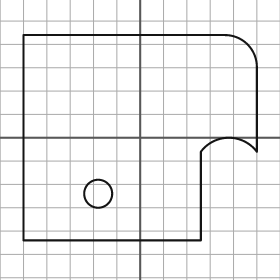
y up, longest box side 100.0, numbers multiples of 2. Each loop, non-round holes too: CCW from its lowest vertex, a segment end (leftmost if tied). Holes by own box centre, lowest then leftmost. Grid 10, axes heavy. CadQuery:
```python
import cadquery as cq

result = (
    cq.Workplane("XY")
    .moveTo(-50.0, -44.0)
    .lineTo(26.0, -44.0)
    .lineTo(26.0, -6.0)
    .threePointArc((38.0, 0.0), (50.0, -6.0))
    .lineTo(50.0, 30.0)
    .threePointArc((46.0, 40.0), (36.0, 44.0))
    .lineTo(-50.0, 44.0)
    .close()
    .moveTo(-18.0, -24.0)
    .circle(6.0)
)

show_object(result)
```